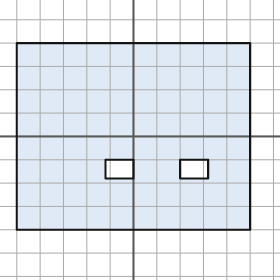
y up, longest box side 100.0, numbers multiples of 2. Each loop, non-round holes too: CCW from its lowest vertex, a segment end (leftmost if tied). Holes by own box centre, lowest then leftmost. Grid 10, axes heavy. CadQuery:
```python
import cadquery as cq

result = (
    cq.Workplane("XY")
    .moveTo(-50.0, -40.0)
    .lineTo(50.0, -40.0)
    .lineTo(50.0, 40.0)
    .lineTo(-50.0, 40.0)
    .close()
    .moveTo(-12.0, -18.0)
    .lineTo(0.0, -18.0)
    .lineTo(0.0, -10.0)
    .lineTo(-12.0, -10.0)
    .close()
    .moveTo(20.0, -18.0)
    .lineTo(32.0, -18.0)
    .lineTo(32.0, -10.0)
    .lineTo(20.0, -10.0)
    .close()
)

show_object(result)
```